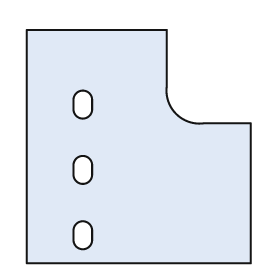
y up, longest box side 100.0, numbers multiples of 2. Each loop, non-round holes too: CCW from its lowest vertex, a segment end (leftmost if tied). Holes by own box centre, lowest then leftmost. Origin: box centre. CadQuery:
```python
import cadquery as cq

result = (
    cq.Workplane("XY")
    .moveTo(-48.0, -50.0)
    .lineTo(48.0, -50.0)
    .lineTo(48.0, 10.0)
    .lineTo(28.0, 10.0)
    .threePointArc((16.0, 14.0), (12.0, 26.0))
    .lineTo(12.0, 50.0)
    .lineTo(-48.0, 50.0)
    .close()
    .moveTo(-28.0, -40.0)
    .threePointArc((-24.0, -44.0), (-20.0, -40.0))
    .lineTo(-20.0, -36.0)
    .threePointArc((-24.0, -32.0), (-28.0, -36.0))
    .close()
    .moveTo(-28.0, -12.0)
    .threePointArc((-24.0, -16.0), (-20.0, -12.0))
    .lineTo(-20.0, -8.0)
    .threePointArc((-24.0, -4.0), (-28.0, -8.0))
    .close()
    .moveTo(-28.0, 16.0)
    .threePointArc((-24.0, 12.0), (-20.0, 16.0))
    .lineTo(-20.0, 20.0)
    .threePointArc((-24.0, 24.0), (-28.0, 20.0))
    .close()
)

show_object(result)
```